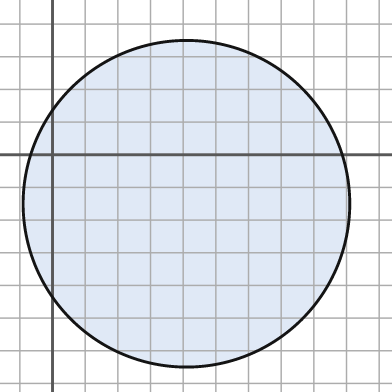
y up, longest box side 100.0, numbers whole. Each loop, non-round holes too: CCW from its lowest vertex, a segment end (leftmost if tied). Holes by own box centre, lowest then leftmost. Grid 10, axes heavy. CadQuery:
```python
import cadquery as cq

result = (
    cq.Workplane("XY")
    .moveTo(41.0, -15.0)
    .circle(50.0)
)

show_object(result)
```